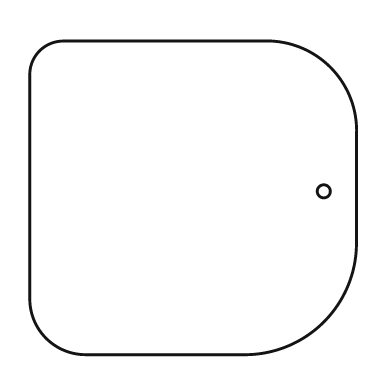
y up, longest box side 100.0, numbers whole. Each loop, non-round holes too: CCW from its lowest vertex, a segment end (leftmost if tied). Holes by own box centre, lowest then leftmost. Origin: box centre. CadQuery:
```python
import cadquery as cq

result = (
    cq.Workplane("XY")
    .moveTo(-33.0, -48.0)
    .lineTo(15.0, -48.0)
    .threePointArc((40.0, -38.0), (50.0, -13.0))
    .lineTo(50.0, 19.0)
    .threePointArc((42.0, 40.0), (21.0, 48.0))
    .lineTo(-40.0, 48.0)
    .threePointArc((-47.0, 45.0), (-50.0, 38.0))
    .lineTo(-50.0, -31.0)
    .threePointArc((-45.0, -43.0), (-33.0, -48.0))
    .close()
    .moveTo(40.0, 2.0)
    .circle(2.0)
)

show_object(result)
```